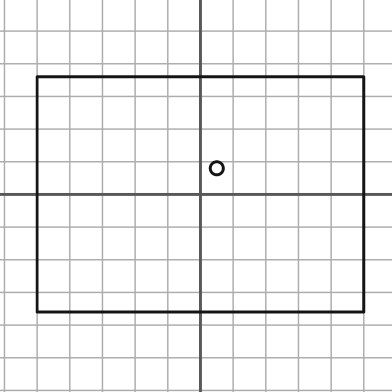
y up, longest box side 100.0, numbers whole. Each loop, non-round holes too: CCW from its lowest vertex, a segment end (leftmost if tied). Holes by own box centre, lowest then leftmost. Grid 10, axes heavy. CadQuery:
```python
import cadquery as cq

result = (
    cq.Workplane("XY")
    .moveTo(-50.0, -36.0)
    .lineTo(50.0, -36.0)
    .lineTo(50.0, 36.0)
    .lineTo(-50.0, 36.0)
    .close()
    .moveTo(5.0, 8.0)
    .circle(2.0)
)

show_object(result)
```